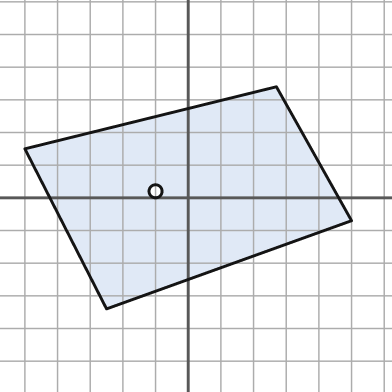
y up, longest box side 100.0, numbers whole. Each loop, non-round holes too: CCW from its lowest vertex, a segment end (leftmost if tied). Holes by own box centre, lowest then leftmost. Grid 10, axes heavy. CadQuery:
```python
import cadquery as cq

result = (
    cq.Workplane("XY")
    .moveTo(-25.0, -34.0)
    .lineTo(50.0, -7.0)
    .lineTo(27.0, 34.0)
    .lineTo(-50.0, 15.0)
    .close()
    .moveTo(-10.0, 2.0)
    .circle(2.0)
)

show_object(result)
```